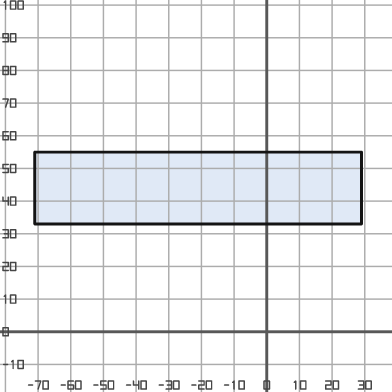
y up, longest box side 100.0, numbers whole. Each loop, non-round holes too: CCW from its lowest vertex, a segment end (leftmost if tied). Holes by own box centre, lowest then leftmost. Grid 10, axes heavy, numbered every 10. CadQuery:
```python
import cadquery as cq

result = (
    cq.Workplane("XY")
    .moveTo(-71.0, 33.0)
    .lineTo(29.0, 33.0)
    .lineTo(29.0, 55.0)
    .lineTo(-71.0, 55.0)
    .close()
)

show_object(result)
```